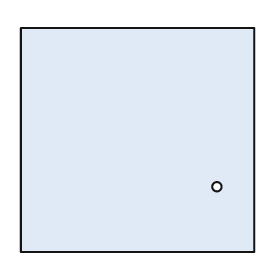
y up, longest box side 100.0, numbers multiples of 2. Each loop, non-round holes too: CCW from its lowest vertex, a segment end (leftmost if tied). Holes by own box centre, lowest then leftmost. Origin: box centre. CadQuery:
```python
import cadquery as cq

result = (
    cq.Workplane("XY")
    .moveTo(-50.0, -48.0)
    .lineTo(50.0, -48.0)
    .lineTo(50.0, 48.0)
    .lineTo(-50.0, 48.0)
    .close()
    .moveTo(34.0, -20.0)
    .circle(2.0)
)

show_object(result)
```